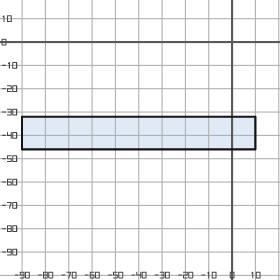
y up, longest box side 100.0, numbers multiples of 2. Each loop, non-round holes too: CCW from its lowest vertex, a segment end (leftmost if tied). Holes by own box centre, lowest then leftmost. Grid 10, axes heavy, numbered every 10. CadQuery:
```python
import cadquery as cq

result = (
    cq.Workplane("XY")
    .moveTo(-90.0, -46.0)
    .lineTo(10.0, -46.0)
    .lineTo(10.0, -32.0)
    .lineTo(-90.0, -32.0)
    .close()
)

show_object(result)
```